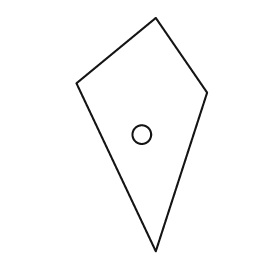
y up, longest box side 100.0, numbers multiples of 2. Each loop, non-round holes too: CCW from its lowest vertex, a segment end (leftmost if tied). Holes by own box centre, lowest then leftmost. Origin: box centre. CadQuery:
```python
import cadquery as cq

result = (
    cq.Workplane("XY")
    .moveTo(6.0, -50.0)
    .lineTo(28.0, 18.0)
    .lineTo(6.0, 50.0)
    .lineTo(-28.0, 22.0)
    .close()
    .moveTo(0.0, 0.0)
    .circle(4.0)
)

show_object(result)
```